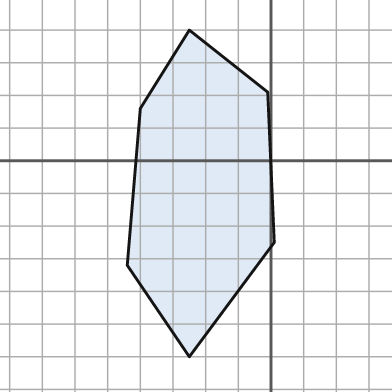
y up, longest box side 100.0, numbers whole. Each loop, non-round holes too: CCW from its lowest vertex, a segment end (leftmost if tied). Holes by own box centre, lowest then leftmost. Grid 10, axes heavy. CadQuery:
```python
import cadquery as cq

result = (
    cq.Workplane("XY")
    .moveTo(-25.0, -60.0)
    .lineTo(1.0, -25.0)
    .lineTo(-1.0, 21.0)
    .lineTo(-25.0, 40.0)
    .lineTo(-40.0, 16.0)
    .lineTo(-44.0, -32.0)
    .close()
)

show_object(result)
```